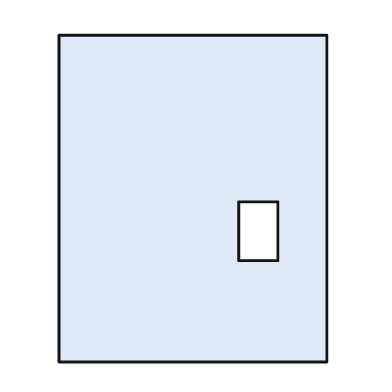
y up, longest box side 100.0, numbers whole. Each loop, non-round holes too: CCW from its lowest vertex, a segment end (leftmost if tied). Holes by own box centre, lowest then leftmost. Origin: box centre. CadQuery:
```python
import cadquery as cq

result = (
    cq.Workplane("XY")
    .moveTo(-41.0, -50.0)
    .lineTo(41.0, -50.0)
    .lineTo(41.0, 50.0)
    .lineTo(-41.0, 50.0)
    .close()
    .moveTo(14.0, -19.0)
    .lineTo(26.0, -19.0)
    .lineTo(26.0, -1.0)
    .lineTo(14.0, -1.0)
    .close()
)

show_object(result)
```